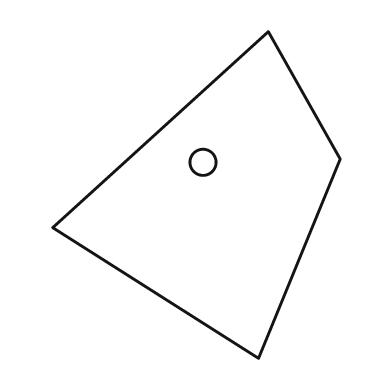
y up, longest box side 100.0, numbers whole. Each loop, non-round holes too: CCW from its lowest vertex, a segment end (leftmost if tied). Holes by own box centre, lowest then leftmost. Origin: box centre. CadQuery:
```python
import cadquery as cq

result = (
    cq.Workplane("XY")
    .moveTo(19.0, -50.0)
    .lineTo(44.0, 11.0)
    .lineTo(22.0, 50.0)
    .lineTo(-44.0, -10.0)
    .close()
    .moveTo(2.0, 10.0)
    .circle(4.0)
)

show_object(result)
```